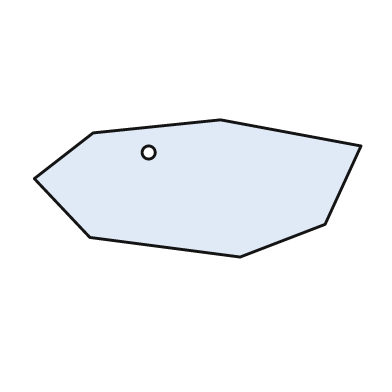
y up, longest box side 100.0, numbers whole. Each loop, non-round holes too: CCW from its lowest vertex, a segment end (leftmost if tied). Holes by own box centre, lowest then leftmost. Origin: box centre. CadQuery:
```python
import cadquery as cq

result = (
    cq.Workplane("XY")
    .moveTo(13.0, -21.0)
    .lineTo(39.0, -11.0)
    .lineTo(50.0, 13.0)
    .lineTo(7.0, 21.0)
    .lineTo(-32.0, 17.0)
    .lineTo(-50.0, 3.0)
    .lineTo(-33.0, -15.0)
    .close()
    .moveTo(-15.0, 11.0)
    .circle(2.0)
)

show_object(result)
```